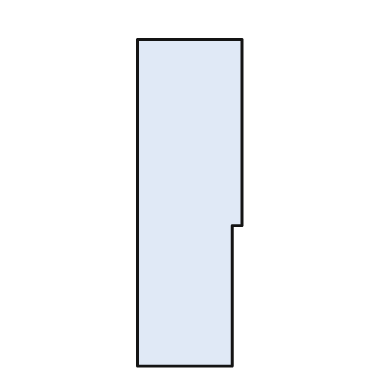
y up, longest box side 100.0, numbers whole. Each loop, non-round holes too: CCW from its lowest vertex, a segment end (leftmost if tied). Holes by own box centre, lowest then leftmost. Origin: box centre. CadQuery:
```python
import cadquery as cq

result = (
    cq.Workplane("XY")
    .moveTo(-16.0, -50.0)
    .lineTo(13.0, -50.0)
    .lineTo(13.0, -7.0)
    .lineTo(16.0, -7.0)
    .lineTo(16.0, 50.0)
    .lineTo(-16.0, 50.0)
    .close()
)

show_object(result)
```